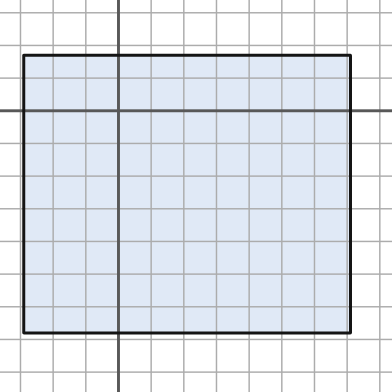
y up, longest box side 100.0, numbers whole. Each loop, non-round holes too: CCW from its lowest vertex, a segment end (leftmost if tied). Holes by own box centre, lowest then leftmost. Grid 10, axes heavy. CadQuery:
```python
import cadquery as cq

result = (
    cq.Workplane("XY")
    .moveTo(-29.0, -68.0)
    .lineTo(71.0, -68.0)
    .lineTo(71.0, 17.0)
    .lineTo(-29.0, 17.0)
    .close()
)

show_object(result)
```